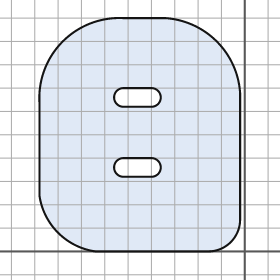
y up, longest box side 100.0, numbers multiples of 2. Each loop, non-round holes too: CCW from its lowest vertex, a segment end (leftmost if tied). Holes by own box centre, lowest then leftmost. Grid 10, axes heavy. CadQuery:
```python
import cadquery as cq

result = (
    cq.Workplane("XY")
    .moveTo(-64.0, 0.0)
    .lineTo(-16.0, 0.0)
    .threePointArc((-6.0, 4.0), (-2.0, 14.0))
    .lineTo(-2.0, 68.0)
    .threePointArc((-12.0, 90.0), (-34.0, 100.0))
    .lineTo(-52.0, 100.0)
    .threePointArc((-78.0, 90.0), (-88.0, 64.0))
    .lineTo(-88.0, 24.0)
    .threePointArc((-80.0, 8.0), (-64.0, 0.0))
    .close()
    .moveTo(-52.0, 32.0)
    .lineTo(-40.0, 32.0)
    .threePointArc((-36.0, 36.0), (-40.0, 40.0))
    .lineTo(-52.0, 40.0)
    .threePointArc((-56.0, 36.0), (-52.0, 32.0))
    .close()
    .moveTo(-52.0, 62.0)
    .lineTo(-40.0, 62.0)
    .threePointArc((-36.0, 66.0), (-40.0, 70.0))
    .lineTo(-52.0, 70.0)
    .threePointArc((-56.0, 66.0), (-52.0, 62.0))
    .close()
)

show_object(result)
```